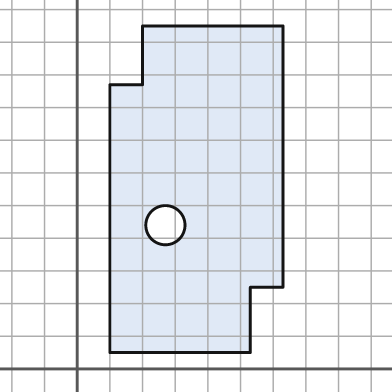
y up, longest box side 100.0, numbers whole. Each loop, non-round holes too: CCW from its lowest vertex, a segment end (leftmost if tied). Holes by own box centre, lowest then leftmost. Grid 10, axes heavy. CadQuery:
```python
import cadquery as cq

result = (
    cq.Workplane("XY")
    .moveTo(10.0, 5.0)
    .lineTo(53.0, 5.0)
    .lineTo(53.0, 25.0)
    .lineTo(63.0, 25.0)
    .lineTo(63.0, 105.0)
    .lineTo(20.0, 105.0)
    .lineTo(20.0, 87.0)
    .lineTo(10.0, 87.0)
    .close()
    .moveTo(27.0, 44.0)
    .circle(6.0)
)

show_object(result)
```